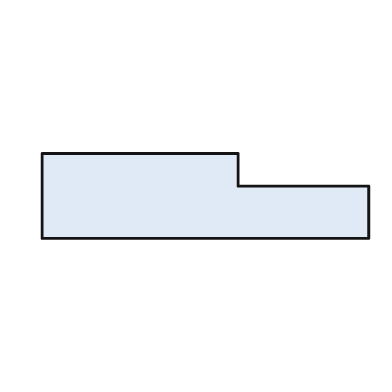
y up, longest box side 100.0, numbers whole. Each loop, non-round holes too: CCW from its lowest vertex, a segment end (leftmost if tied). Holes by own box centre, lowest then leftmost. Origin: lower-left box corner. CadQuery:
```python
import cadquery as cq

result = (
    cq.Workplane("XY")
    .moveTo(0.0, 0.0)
    .lineTo(100.0, 0.0)
    .lineTo(100.0, 16.0)
    .lineTo(60.0, 16.0)
    .lineTo(60.0, 26.0)
    .lineTo(0.0, 26.0)
    .close()
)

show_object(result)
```